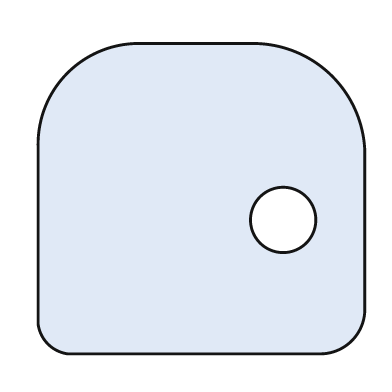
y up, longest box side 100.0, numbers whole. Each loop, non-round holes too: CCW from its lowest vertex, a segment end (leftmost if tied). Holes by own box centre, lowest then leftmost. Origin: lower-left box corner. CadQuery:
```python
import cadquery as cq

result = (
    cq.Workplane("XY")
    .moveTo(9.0, 0.0)
    .lineTo(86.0, 0.0)
    .threePointArc((96.0, 4.0), (100.0, 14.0))
    .lineTo(100.0, 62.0)
    .threePointArc((90.0, 85.0), (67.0, 95.0))
    .lineTo(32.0, 95.0)
    .threePointArc((9.0, 86.0), (0.0, 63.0))
    .lineTo(0.0, 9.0)
    .threePointArc((3.0, 3.0), (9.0, 0.0))
    .close()
    .moveTo(75.0, 41.0)
    .circle(10.0)
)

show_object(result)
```